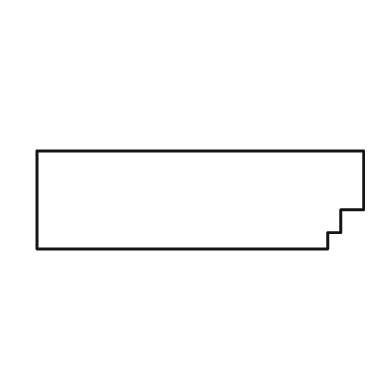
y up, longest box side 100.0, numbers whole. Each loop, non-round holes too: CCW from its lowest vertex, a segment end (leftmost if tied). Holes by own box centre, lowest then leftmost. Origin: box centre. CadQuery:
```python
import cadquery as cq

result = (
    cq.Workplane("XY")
    .moveTo(-50.0, -15.0)
    .lineTo(39.0, -15.0)
    .lineTo(39.0, -10.0)
    .lineTo(43.0, -10.0)
    .lineTo(43.0, -3.0)
    .lineTo(50.0, -3.0)
    .lineTo(50.0, 15.0)
    .lineTo(-50.0, 15.0)
    .close()
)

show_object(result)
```